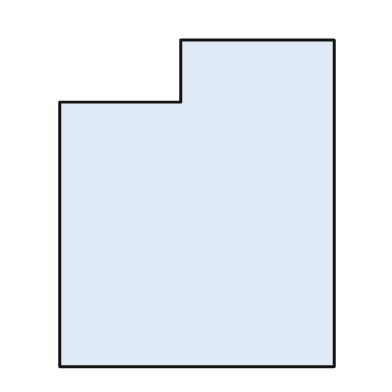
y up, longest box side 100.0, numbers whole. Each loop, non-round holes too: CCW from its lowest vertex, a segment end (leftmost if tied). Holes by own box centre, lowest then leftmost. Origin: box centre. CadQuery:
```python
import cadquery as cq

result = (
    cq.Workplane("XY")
    .moveTo(-42.0, -50.0)
    .lineTo(42.0, -50.0)
    .lineTo(42.0, 50.0)
    .lineTo(-5.0, 50.0)
    .lineTo(-5.0, 31.0)
    .lineTo(-42.0, 31.0)
    .close()
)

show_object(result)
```